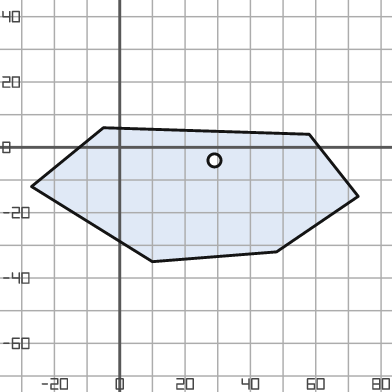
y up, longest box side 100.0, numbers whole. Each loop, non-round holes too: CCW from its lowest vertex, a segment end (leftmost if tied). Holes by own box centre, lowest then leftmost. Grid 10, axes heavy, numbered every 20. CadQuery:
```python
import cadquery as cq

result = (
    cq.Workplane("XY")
    .moveTo(10.0, -35.0)
    .lineTo(48.0, -32.0)
    .lineTo(73.0, -15.0)
    .lineTo(58.0, 4.0)
    .lineTo(-5.0, 6.0)
    .lineTo(-27.0, -12.0)
    .close()
    .moveTo(29.0, -4.0)
    .circle(2.0)
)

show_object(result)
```